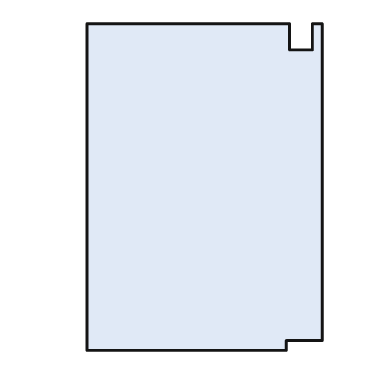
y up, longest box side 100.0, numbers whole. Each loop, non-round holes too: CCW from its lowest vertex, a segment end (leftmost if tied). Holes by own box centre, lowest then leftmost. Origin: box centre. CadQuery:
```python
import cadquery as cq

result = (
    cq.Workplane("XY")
    .moveTo(-36.0, -50.0)
    .lineTo(25.0, -50.0)
    .lineTo(25.0, -47.0)
    .lineTo(36.0, -47.0)
    .lineTo(36.0, 50.0)
    .lineTo(33.0, 50.0)
    .lineTo(33.0, 42.0)
    .lineTo(26.0, 42.0)
    .lineTo(26.0, 50.0)
    .lineTo(-36.0, 50.0)
    .close()
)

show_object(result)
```